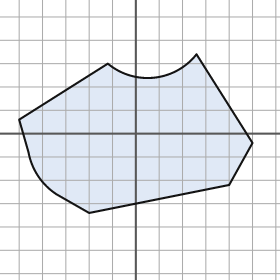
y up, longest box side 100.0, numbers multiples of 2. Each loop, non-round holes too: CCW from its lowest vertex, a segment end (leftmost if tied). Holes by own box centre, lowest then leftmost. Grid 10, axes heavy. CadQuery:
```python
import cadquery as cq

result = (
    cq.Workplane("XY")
    .moveTo(-20.0, -34.0)
    .lineTo(40.0, -22.0)
    .lineTo(50.0, -4.0)
    .lineTo(26.0, 34.0)
    .threePointArc((8.0, 24.0), (-12.0, 30.0))
    .lineTo(-50.0, 6.0)
    .lineTo(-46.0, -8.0)
    .threePointArc((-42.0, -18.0), (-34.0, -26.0))
    .close()
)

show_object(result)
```